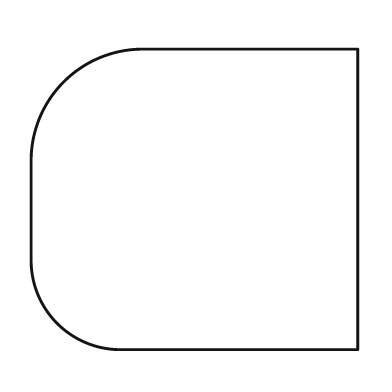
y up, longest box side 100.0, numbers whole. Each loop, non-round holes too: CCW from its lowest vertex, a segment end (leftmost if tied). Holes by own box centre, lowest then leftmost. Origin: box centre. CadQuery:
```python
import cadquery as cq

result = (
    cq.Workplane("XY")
    .moveTo(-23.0, -46.0)
    .lineTo(50.0, -46.0)
    .lineTo(50.0, 46.0)
    .lineTo(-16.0, 46.0)
    .threePointArc((-40.0, 36.0), (-50.0, 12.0))
    .lineTo(-50.0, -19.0)
    .threePointArc((-42.0, -38.0), (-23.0, -46.0))
    .close()
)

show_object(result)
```